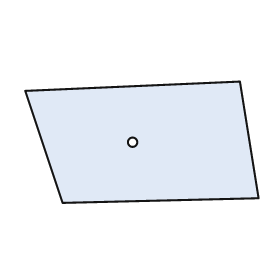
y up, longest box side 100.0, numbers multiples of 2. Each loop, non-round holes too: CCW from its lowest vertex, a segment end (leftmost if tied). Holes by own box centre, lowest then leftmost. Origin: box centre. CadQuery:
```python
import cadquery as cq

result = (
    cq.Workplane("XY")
    .moveTo(-34.0, -26.0)
    .lineTo(50.0, -24.0)
    .lineTo(42.0, 26.0)
    .lineTo(-50.0, 22.0)
    .close()
    .moveTo(-4.0, 0.0)
    .circle(2.0)
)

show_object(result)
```